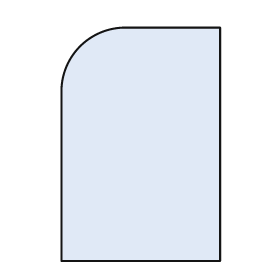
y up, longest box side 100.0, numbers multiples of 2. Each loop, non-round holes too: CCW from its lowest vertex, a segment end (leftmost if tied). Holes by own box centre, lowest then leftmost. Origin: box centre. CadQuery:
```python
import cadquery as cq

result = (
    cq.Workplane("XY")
    .moveTo(-34.0, -50.0)
    .lineTo(34.0, -50.0)
    .lineTo(34.0, 50.0)
    .lineTo(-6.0, 50.0)
    .threePointArc((-26.0, 42.0), (-34.0, 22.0))
    .close()
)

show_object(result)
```